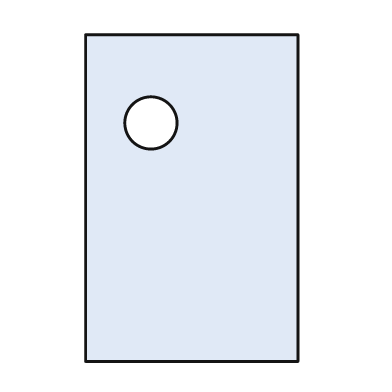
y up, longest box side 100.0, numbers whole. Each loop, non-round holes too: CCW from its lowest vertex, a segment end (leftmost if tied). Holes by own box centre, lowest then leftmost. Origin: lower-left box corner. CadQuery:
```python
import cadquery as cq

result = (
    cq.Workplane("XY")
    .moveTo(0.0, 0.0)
    .lineTo(65.0, 0.0)
    .lineTo(65.0, 100.0)
    .lineTo(0.0, 100.0)
    .close()
    .moveTo(20.0, 73.0)
    .circle(8.0)
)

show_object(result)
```